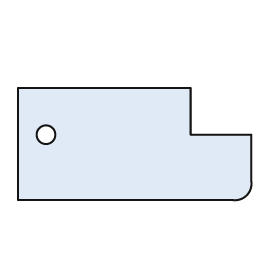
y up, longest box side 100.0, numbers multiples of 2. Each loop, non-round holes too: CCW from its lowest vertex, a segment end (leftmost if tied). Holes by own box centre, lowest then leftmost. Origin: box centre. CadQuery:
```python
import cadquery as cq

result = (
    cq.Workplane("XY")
    .moveTo(-50.0, -24.0)
    .lineTo(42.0, -24.0)
    .threePointArc((48.0, -22.0), (50.0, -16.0))
    .lineTo(50.0, 4.0)
    .lineTo(24.0, 4.0)
    .lineTo(24.0, 24.0)
    .lineTo(-50.0, 24.0)
    .close()
    .moveTo(-38.0, 4.0)
    .circle(4.0)
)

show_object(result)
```